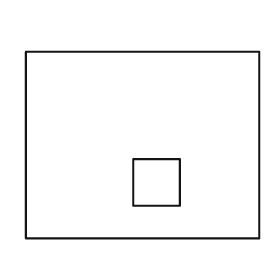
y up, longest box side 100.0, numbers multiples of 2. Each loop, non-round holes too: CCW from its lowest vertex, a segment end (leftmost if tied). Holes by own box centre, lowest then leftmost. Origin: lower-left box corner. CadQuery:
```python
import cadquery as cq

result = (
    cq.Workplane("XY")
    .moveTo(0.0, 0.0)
    .lineTo(100.0, 0.0)
    .lineTo(100.0, 80.0)
    .lineTo(0.0, 80.0)
    .close()
    .moveTo(46.0, 14.0)
    .lineTo(66.0, 14.0)
    .lineTo(66.0, 34.0)
    .lineTo(46.0, 34.0)
    .close()
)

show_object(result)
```